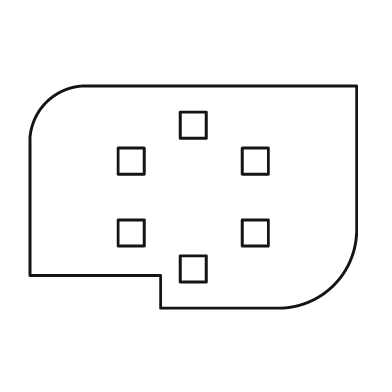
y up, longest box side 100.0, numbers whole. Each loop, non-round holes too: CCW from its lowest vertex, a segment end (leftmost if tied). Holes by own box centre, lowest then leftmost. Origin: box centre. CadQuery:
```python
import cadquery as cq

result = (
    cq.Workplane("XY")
    .moveTo(-10.0, -34.0)
    .lineTo(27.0, -34.0)
    .threePointArc((43.0, -27.0), (50.0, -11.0))
    .lineTo(50.0, 34.0)
    .lineTo(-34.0, 34.0)
    .threePointArc((-45.0, 29.0), (-50.0, 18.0))
    .lineTo(-50.0, -24.0)
    .lineTo(-10.0, -24.0)
    .close()
    .moveTo(-4.0, -26.0)
    .lineTo(4.0, -26.0)
    .lineTo(4.0, -18.0)
    .lineTo(-4.0, -18.0)
    .close()
    .moveTo(-23.0, -15.0)
    .lineTo(-15.0, -15.0)
    .lineTo(-15.0, -7.0)
    .lineTo(-23.0, -7.0)
    .close()
    .moveTo(15.0, -15.0)
    .lineTo(23.0, -15.0)
    .lineTo(23.0, -7.0)
    .lineTo(15.0, -7.0)
    .close()
    .moveTo(-23.0, 7.0)
    .lineTo(-15.0, 7.0)
    .lineTo(-15.0, 15.0)
    .lineTo(-23.0, 15.0)
    .close()
    .moveTo(15.0, 7.0)
    .lineTo(23.0, 7.0)
    .lineTo(23.0, 15.0)
    .lineTo(15.0, 15.0)
    .close()
    .moveTo(-4.0, 18.0)
    .lineTo(4.0, 18.0)
    .lineTo(4.0, 26.0)
    .lineTo(-4.0, 26.0)
    .close()
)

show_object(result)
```